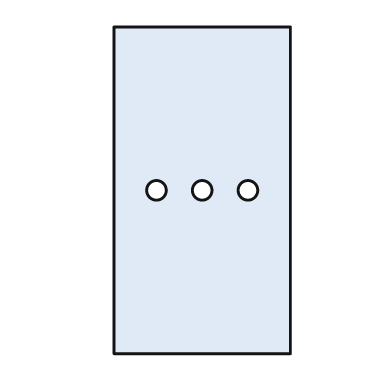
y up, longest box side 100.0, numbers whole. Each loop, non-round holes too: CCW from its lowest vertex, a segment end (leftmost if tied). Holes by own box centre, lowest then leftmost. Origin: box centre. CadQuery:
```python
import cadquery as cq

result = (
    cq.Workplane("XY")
    .moveTo(-27.0, -50.0)
    .lineTo(27.0, -50.0)
    .lineTo(27.0, 50.0)
    .lineTo(-27.0, 50.0)
    .close()
    .moveTo(-14.0, 0.0)
    .circle(3.0)
    .moveTo(0.0, 0.0)
    .circle(3.0)
    .moveTo(14.0, 0.0)
    .circle(3.0)
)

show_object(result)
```